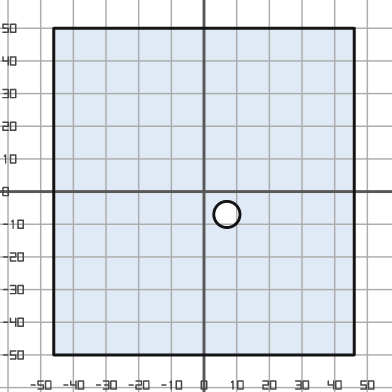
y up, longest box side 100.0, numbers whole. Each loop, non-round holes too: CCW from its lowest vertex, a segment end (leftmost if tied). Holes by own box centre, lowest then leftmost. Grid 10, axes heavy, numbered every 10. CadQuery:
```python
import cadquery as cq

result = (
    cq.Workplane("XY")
    .moveTo(-46.0, -50.0)
    .lineTo(46.0, -50.0)
    .lineTo(46.0, 50.0)
    .lineTo(-46.0, 50.0)
    .close()
    .moveTo(7.0, -7.0)
    .circle(4.0)
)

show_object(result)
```